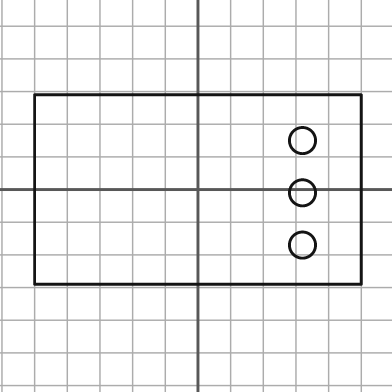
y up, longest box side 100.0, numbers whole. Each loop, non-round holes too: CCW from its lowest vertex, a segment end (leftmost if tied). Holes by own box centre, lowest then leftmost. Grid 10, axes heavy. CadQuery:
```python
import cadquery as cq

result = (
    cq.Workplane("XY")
    .moveTo(-50.0, -29.0)
    .lineTo(50.0, -29.0)
    .lineTo(50.0, 29.0)
    .lineTo(-50.0, 29.0)
    .close()
    .moveTo(32.0, -17.0)
    .circle(4.0)
    .moveTo(32.0, -1.0)
    .circle(4.0)
    .moveTo(32.0, 15.0)
    .circle(4.0)
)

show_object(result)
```